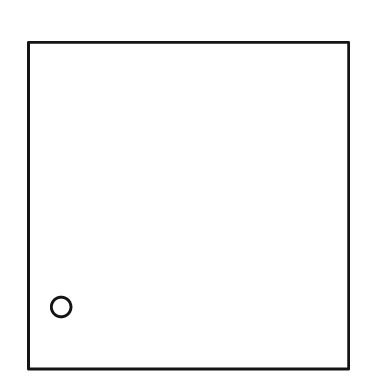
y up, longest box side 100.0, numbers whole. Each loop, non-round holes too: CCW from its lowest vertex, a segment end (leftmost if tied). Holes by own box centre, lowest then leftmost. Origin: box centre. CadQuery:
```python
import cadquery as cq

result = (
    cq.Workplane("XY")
    .moveTo(-49.0, -50.0)
    .lineTo(49.0, -50.0)
    .lineTo(49.0, 50.0)
    .lineTo(-49.0, 50.0)
    .close()
    .moveTo(-39.0, -31.0)
    .circle(3.0)
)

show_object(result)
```